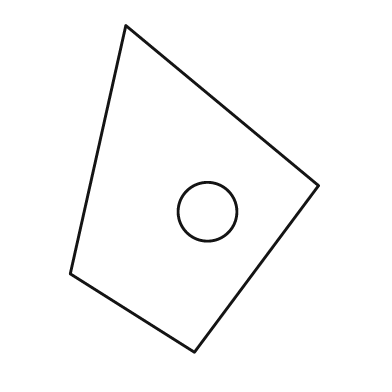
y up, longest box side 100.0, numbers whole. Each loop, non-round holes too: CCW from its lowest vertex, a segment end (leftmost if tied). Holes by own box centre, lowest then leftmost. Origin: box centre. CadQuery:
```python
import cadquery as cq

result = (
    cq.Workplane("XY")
    .moveTo(0.0, -50.0)
    .lineTo(38.0, 1.0)
    .lineTo(-21.0, 50.0)
    .lineTo(-38.0, -26.0)
    .close()
    .moveTo(4.0, -7.0)
    .circle(9.0)
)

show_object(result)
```